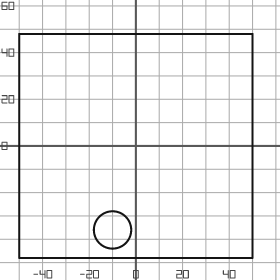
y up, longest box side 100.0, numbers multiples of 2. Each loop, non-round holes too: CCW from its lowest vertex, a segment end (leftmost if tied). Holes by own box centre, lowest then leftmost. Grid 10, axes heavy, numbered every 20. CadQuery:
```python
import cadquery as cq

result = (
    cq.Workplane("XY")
    .moveTo(-50.0, -48.0)
    .lineTo(50.0, -48.0)
    .lineTo(50.0, 48.0)
    .lineTo(-50.0, 48.0)
    .close()
    .moveTo(-10.0, -36.0)
    .circle(8.0)
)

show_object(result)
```